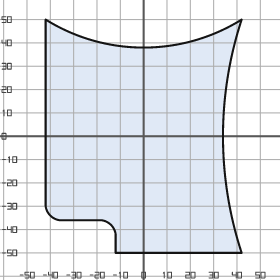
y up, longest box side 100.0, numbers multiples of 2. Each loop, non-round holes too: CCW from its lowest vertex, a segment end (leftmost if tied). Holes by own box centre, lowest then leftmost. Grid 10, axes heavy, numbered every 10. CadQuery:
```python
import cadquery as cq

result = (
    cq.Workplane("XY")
    .moveTo(-12.0, -50.0)
    .lineTo(42.0, -50.0)
    .threePointArc((34.0, 0.0), (42.0, 50.0))
    .threePointArc((0.0, 38.0), (-42.0, 50.0))
    .lineTo(-42.0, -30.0)
    .threePointArc((-40.0, -34.0), (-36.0, -36.0))
    .lineTo(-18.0, -36.0)
    .threePointArc((-14.0, -38.0), (-12.0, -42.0))
    .close()
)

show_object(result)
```